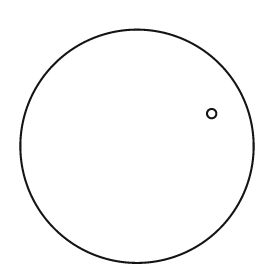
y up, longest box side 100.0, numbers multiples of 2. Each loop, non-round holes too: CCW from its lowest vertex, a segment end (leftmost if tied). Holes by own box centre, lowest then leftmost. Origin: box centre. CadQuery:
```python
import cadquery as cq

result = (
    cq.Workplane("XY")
    .moveTo(0.0, 0.0)
    .circle(50.0)
    .moveTo(32.0, 14.0)
    .circle(2.0)
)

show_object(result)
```